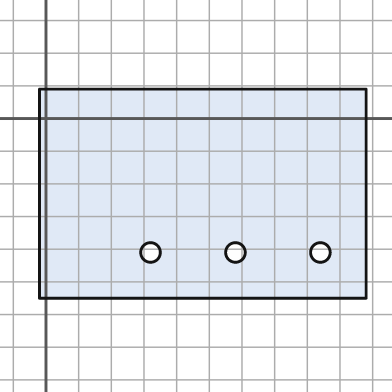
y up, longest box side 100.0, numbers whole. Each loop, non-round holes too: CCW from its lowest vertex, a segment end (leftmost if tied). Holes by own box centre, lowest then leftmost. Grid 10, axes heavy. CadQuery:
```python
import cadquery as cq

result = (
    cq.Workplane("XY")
    .moveTo(-2.0, -55.0)
    .lineTo(98.0, -55.0)
    .lineTo(98.0, 9.0)
    .lineTo(-2.0, 9.0)
    .close()
    .moveTo(32.0, -41.0)
    .circle(3.0)
    .moveTo(58.0, -41.0)
    .circle(3.0)
    .moveTo(84.0, -41.0)
    .circle(3.0)
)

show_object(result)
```